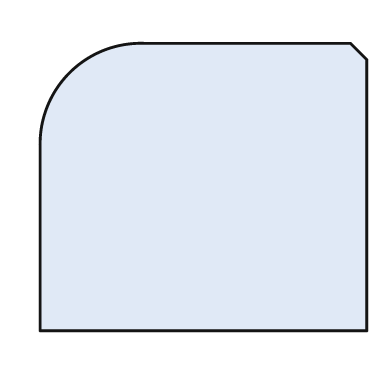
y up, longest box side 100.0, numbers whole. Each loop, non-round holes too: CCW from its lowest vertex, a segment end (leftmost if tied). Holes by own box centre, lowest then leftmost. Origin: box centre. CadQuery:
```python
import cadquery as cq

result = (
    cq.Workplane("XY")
    .moveTo(-50.0, -44.0)
    .lineTo(50.0, -44.0)
    .lineTo(50.0, 39.0)
    .lineTo(45.0, 44.0)
    .lineTo(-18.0, 44.0)
    .threePointArc((-41.0, 35.0), (-50.0, 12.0))
    .close()
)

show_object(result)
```